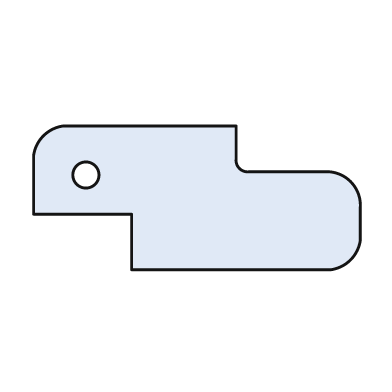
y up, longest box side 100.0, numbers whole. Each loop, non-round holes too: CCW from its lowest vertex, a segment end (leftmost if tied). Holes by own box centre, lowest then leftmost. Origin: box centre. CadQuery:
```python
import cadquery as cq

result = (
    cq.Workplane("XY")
    .moveTo(-20.0, -22.0)
    .lineTo(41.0, -22.0)
    .threePointArc((47.0, -19.0), (50.0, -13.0))
    .lineTo(50.0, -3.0)
    .threePointArc((47.0, 5.0), (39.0, 8.0))
    .lineTo(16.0, 8.0)
    .threePointArc((13.0, 9.0), (12.0, 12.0))
    .lineTo(12.0, 22.0)
    .lineTo(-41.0, 22.0)
    .threePointArc((-47.0, 19.0), (-50.0, 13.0))
    .lineTo(-50.0, -5.0)
    .lineTo(-20.0, -5.0)
    .close()
    .moveTo(-34.0, 7.0)
    .circle(4.0)
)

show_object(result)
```